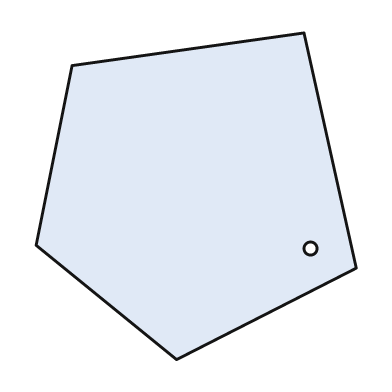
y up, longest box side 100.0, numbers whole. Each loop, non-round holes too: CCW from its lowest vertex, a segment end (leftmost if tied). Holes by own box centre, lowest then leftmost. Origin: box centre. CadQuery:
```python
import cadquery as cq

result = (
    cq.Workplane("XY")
    .moveTo(-6.0, -50.0)
    .lineTo(49.0, -22.0)
    .lineTo(33.0, 50.0)
    .lineTo(-38.0, 40.0)
    .lineTo(-49.0, -15.0)
    .close()
    .moveTo(35.0, -16.0)
    .circle(2.0)
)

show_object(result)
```